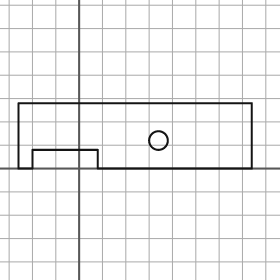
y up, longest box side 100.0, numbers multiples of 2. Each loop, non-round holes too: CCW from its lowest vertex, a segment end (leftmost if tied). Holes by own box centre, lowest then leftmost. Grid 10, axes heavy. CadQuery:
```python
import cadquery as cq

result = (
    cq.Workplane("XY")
    .moveTo(-26.0, 0.0)
    .lineTo(-20.0, 0.0)
    .lineTo(-20.0, 8.0)
    .lineTo(8.0, 8.0)
    .lineTo(8.0, 0.0)
    .lineTo(74.0, 0.0)
    .lineTo(74.0, 28.0)
    .lineTo(-26.0, 28.0)
    .close()
    .moveTo(34.0, 12.0)
    .circle(4.0)
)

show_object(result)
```